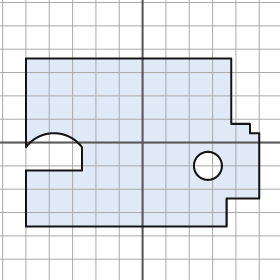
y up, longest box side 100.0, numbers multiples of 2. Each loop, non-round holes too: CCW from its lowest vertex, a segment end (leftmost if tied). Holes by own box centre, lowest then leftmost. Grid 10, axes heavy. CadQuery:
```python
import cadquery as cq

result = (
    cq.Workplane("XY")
    .moveTo(-50.0, -36.0)
    .lineTo(36.0, -36.0)
    .lineTo(36.0, -24.0)
    .lineTo(50.0, -24.0)
    .lineTo(50.0, 4.0)
    .lineTo(46.0, 4.0)
    .lineTo(46.0, 8.0)
    .lineTo(38.0, 8.0)
    .lineTo(38.0, 36.0)
    .lineTo(-50.0, 36.0)
    .lineTo(-50.0, -2.0)
    .threePointArc((-38.0, 4.0), (-26.0, -2.0))
    .lineTo(-26.0, -12.0)
    .lineTo(-50.0, -12.0)
    .close()
    .moveTo(28.0, -10.0)
    .circle(6.0)
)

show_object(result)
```